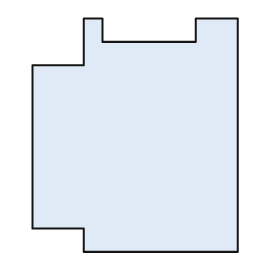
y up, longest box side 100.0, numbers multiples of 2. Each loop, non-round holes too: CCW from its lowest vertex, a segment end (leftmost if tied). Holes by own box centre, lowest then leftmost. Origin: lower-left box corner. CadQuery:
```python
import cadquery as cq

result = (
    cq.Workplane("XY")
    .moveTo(22.0, 0.0)
    .lineTo(88.0, 0.0)
    .lineTo(88.0, 100.0)
    .lineTo(70.0, 100.0)
    .lineTo(70.0, 90.0)
    .lineTo(30.0, 90.0)
    .lineTo(30.0, 100.0)
    .lineTo(22.0, 100.0)
    .lineTo(22.0, 80.0)
    .lineTo(0.0, 80.0)
    .lineTo(0.0, 10.0)
    .lineTo(22.0, 10.0)
    .close()
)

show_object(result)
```